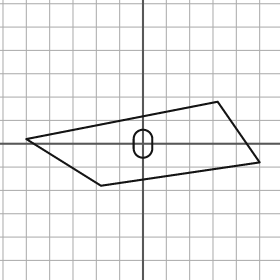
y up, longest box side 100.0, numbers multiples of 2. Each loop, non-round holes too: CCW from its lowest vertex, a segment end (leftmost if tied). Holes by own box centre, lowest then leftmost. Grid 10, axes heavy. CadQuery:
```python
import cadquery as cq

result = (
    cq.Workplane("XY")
    .moveTo(-18.0, -18.0)
    .lineTo(50.0, -8.0)
    .lineTo(32.0, 18.0)
    .lineTo(-50.0, 2.0)
    .close()
    .moveTo(-4.0, -2.0)
    .threePointArc((0.0, -6.0), (4.0, -2.0))
    .lineTo(4.0, 2.0)
    .threePointArc((0.0, 6.0), (-4.0, 2.0))
    .close()
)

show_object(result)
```